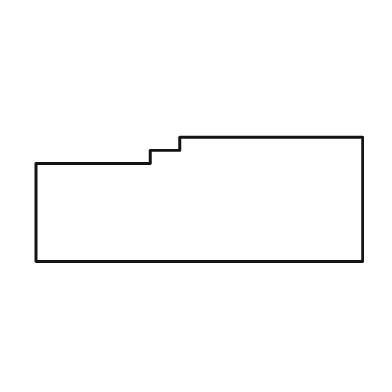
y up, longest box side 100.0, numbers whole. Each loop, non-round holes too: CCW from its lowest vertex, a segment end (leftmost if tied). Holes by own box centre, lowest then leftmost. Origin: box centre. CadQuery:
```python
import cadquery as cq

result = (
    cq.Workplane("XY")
    .moveTo(-50.0, -19.0)
    .lineTo(50.0, -19.0)
    .lineTo(50.0, 19.0)
    .lineTo(-6.0, 19.0)
    .lineTo(-6.0, 15.0)
    .lineTo(-15.0, 15.0)
    .lineTo(-15.0, 11.0)
    .lineTo(-50.0, 11.0)
    .close()
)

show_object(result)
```